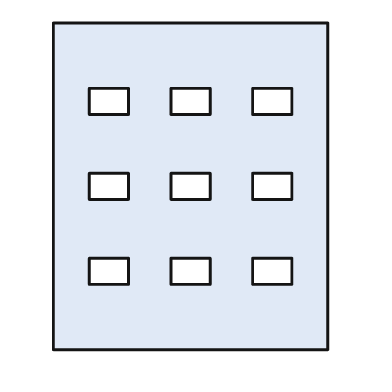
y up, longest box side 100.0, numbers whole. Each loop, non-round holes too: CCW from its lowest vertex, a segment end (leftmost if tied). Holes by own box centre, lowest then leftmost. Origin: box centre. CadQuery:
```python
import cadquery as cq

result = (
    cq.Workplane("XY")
    .moveTo(-42.0, -50.0)
    .lineTo(42.0, -50.0)
    .lineTo(42.0, 50.0)
    .lineTo(-42.0, 50.0)
    .close()
    .moveTo(-31.0, -30.0)
    .lineTo(-19.0, -30.0)
    .lineTo(-19.0, -22.0)
    .lineTo(-31.0, -22.0)
    .close()
    .moveTo(-6.0, -30.0)
    .lineTo(6.0, -30.0)
    .lineTo(6.0, -22.0)
    .lineTo(-6.0, -22.0)
    .close()
    .moveTo(19.0, -30.0)
    .lineTo(31.0, -30.0)
    .lineTo(31.0, -22.0)
    .lineTo(19.0, -22.0)
    .close()
    .moveTo(-31.0, -4.0)
    .lineTo(-19.0, -4.0)
    .lineTo(-19.0, 4.0)
    .lineTo(-31.0, 4.0)
    .close()
    .moveTo(-6.0, -4.0)
    .lineTo(6.0, -4.0)
    .lineTo(6.0, 4.0)
    .lineTo(-6.0, 4.0)
    .close()
    .moveTo(19.0, -4.0)
    .lineTo(31.0, -4.0)
    .lineTo(31.0, 4.0)
    .lineTo(19.0, 4.0)
    .close()
    .moveTo(-31.0, 22.0)
    .lineTo(-19.0, 22.0)
    .lineTo(-19.0, 30.0)
    .lineTo(-31.0, 30.0)
    .close()
    .moveTo(-6.0, 22.0)
    .lineTo(6.0, 22.0)
    .lineTo(6.0, 30.0)
    .lineTo(-6.0, 30.0)
    .close()
    .moveTo(19.0, 22.0)
    .lineTo(31.0, 22.0)
    .lineTo(31.0, 30.0)
    .lineTo(19.0, 30.0)
    .close()
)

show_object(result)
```